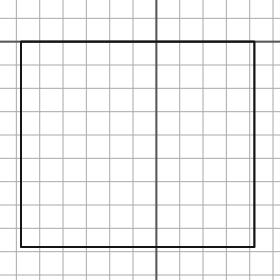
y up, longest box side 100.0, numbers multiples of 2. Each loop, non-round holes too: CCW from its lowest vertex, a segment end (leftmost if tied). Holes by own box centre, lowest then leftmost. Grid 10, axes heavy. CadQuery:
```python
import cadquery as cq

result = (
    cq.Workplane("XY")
    .moveTo(-58.0, -88.0)
    .lineTo(42.0, -88.0)
    .lineTo(42.0, 0.0)
    .lineTo(-58.0, 0.0)
    .close()
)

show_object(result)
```